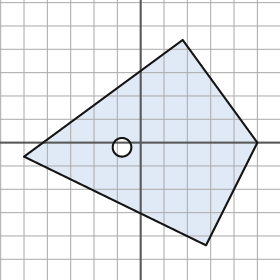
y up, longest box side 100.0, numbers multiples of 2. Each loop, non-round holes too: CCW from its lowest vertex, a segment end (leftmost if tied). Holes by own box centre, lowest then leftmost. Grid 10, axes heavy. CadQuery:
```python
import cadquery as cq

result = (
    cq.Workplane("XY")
    .moveTo(28.0, -44.0)
    .lineTo(50.0, 0.0)
    .lineTo(18.0, 44.0)
    .lineTo(-50.0, -6.0)
    .close()
    .moveTo(-8.0, -2.0)
    .circle(4.0)
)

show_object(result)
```